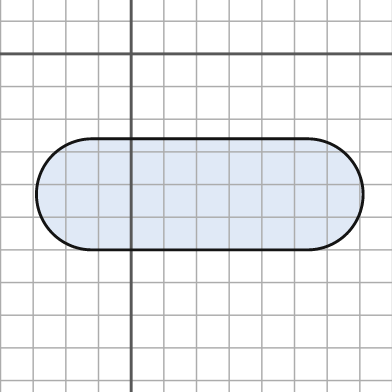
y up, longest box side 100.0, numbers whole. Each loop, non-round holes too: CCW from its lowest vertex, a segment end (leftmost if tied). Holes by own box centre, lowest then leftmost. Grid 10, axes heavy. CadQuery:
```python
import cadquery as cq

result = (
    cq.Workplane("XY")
    .moveTo(-12.0, -60.0)
    .lineTo(54.0, -60.0)
    .threePointArc((71.0, -43.0), (54.0, -26.0))
    .lineTo(-12.0, -26.0)
    .threePointArc((-29.0, -43.0), (-12.0, -60.0))
    .close()
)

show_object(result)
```